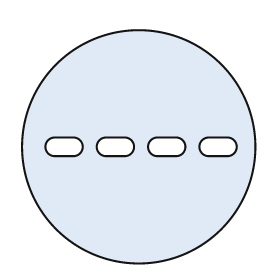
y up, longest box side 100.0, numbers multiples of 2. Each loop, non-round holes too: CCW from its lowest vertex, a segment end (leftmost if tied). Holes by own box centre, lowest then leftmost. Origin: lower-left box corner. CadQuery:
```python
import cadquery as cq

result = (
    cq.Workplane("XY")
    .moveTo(50.0, 50.0)
    .circle(50.0)
    .moveTo(14.0, 46.0)
    .lineTo(22.0, 46.0)
    .threePointArc((26.0, 50.0), (22.0, 54.0))
    .lineTo(14.0, 54.0)
    .threePointArc((10.0, 50.0), (14.0, 46.0))
    .close()
    .moveTo(36.0, 46.0)
    .lineTo(44.0, 46.0)
    .threePointArc((48.0, 50.0), (44.0, 54.0))
    .lineTo(36.0, 54.0)
    .threePointArc((32.0, 50.0), (36.0, 46.0))
    .close()
    .moveTo(58.0, 46.0)
    .lineTo(66.0, 46.0)
    .threePointArc((70.0, 50.0), (66.0, 54.0))
    .lineTo(58.0, 54.0)
    .threePointArc((54.0, 50.0), (58.0, 46.0))
    .close()
    .moveTo(80.0, 46.0)
    .lineTo(88.0, 46.0)
    .threePointArc((92.0, 50.0), (88.0, 54.0))
    .lineTo(80.0, 54.0)
    .threePointArc((76.0, 50.0), (80.0, 46.0))
    .close()
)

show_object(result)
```